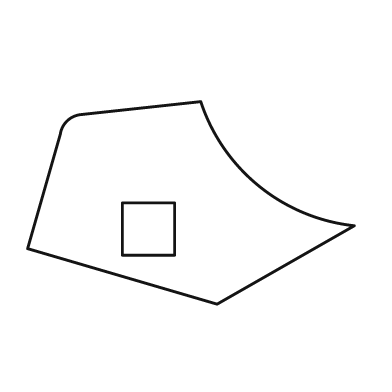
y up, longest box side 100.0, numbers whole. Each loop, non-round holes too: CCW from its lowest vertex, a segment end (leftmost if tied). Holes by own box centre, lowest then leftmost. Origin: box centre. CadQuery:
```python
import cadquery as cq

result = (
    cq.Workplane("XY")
    .moveTo(8.0, -31.0)
    .lineTo(50.0, -7.0)
    .threePointArc((21.0, 5.0), (3.0, 31.0))
    .lineTo(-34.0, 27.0)
    .threePointArc((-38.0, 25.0), (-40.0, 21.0))
    .lineTo(-50.0, -14.0)
    .close()
    .moveTo(-21.0, -16.0)
    .lineTo(-5.0, -16.0)
    .lineTo(-5.0, 0.0)
    .lineTo(-21.0, 0.0)
    .close()
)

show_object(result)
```